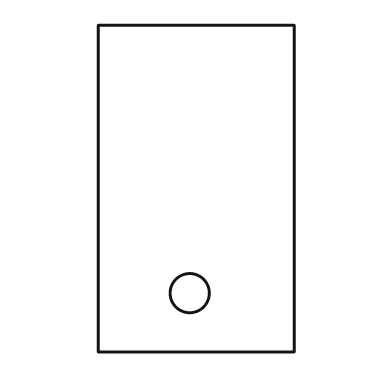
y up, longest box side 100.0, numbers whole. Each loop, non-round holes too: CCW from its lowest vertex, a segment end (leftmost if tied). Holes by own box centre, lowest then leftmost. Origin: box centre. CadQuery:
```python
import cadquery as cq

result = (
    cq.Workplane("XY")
    .moveTo(-30.0, -50.0)
    .lineTo(30.0, -50.0)
    .lineTo(30.0, 50.0)
    .lineTo(-30.0, 50.0)
    .close()
    .moveTo(-2.0, -32.0)
    .circle(6.0)
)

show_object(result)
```